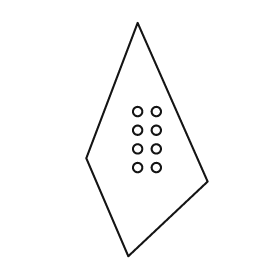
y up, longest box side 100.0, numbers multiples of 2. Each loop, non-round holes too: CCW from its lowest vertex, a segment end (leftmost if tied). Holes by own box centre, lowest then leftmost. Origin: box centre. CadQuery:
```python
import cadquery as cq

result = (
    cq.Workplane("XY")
    .moveTo(-8.0, -50.0)
    .lineTo(26.0, -18.0)
    .lineTo(-4.0, 50.0)
    .lineTo(-26.0, -8.0)
    .close()
    .moveTo(-4.0, -12.0)
    .circle(2.0)
    .moveTo(4.0, -12.0)
    .circle(2.0)
    .moveTo(-4.0, -4.0)
    .circle(2.0)
    .moveTo(4.0, -4.0)
    .circle(2.0)
    .moveTo(-4.0, 4.0)
    .circle(2.0)
    .moveTo(4.0, 4.0)
    .circle(2.0)
    .moveTo(-4.0, 12.0)
    .circle(2.0)
    .moveTo(4.0, 12.0)
    .circle(2.0)
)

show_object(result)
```